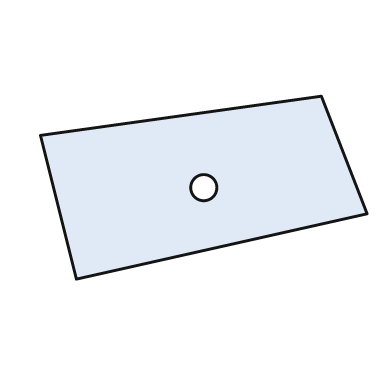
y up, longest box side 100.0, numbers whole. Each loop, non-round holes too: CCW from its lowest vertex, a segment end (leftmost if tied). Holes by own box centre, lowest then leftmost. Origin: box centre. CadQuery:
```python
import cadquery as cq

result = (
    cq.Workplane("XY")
    .moveTo(-39.0, -28.0)
    .lineTo(50.0, -8.0)
    .lineTo(36.0, 28.0)
    .lineTo(-50.0, 16.0)
    .close()
    .moveTo(0.0, 0.0)
    .circle(4.0)
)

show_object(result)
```